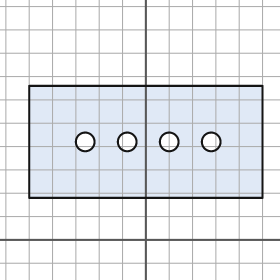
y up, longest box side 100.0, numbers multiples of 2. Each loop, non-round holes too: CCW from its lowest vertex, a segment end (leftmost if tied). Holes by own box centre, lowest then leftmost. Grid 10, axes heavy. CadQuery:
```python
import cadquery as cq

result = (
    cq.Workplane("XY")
    .moveTo(-50.0, 18.0)
    .lineTo(50.0, 18.0)
    .lineTo(50.0, 66.0)
    .lineTo(-50.0, 66.0)
    .close()
    .moveTo(-26.0, 42.0)
    .circle(4.0)
    .moveTo(-8.0, 42.0)
    .circle(4.0)
    .moveTo(10.0, 42.0)
    .circle(4.0)
    .moveTo(28.0, 42.0)
    .circle(4.0)
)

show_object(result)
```